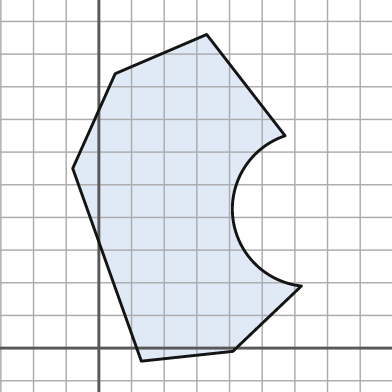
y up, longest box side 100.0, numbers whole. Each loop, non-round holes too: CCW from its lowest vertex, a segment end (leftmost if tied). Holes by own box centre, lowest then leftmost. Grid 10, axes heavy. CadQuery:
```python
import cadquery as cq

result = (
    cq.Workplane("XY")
    .moveTo(13.0, -4.0)
    .lineTo(41.0, -1.0)
    .lineTo(62.0, 19.0)
    .threePointArc((41.0, 40.0), (57.0, 65.0))
    .lineTo(33.0, 96.0)
    .lineTo(5.0, 84.0)
    .lineTo(-8.0, 55.0)
    .close()
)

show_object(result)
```